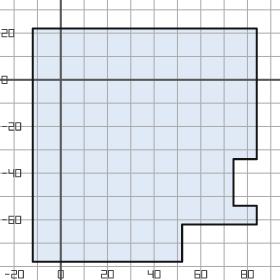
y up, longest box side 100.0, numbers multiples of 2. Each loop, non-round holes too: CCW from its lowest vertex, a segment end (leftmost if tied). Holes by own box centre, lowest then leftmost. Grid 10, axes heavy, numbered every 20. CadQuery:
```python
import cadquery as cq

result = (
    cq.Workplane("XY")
    .moveTo(-12.0, -78.0)
    .lineTo(52.0, -78.0)
    .lineTo(52.0, -62.0)
    .lineTo(84.0, -62.0)
    .lineTo(84.0, -54.0)
    .lineTo(74.0, -54.0)
    .lineTo(74.0, -34.0)
    .lineTo(84.0, -34.0)
    .lineTo(84.0, 22.0)
    .lineTo(-12.0, 22.0)
    .close()
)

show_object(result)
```